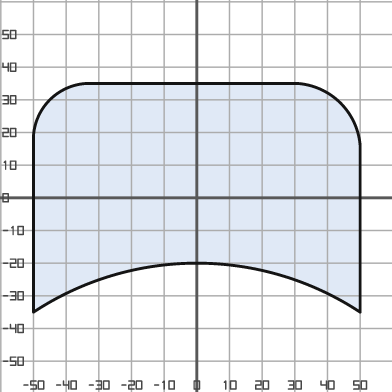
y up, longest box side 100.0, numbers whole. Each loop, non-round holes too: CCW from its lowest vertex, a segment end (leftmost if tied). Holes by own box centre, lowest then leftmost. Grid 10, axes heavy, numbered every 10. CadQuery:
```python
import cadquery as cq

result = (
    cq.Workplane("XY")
    .moveTo(-50.0, -35.0)
    .threePointArc((0.0, -20.0), (50.0, -35.0))
    .lineTo(50.0, 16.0)
    .threePointArc((44.0, 29.0), (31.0, 35.0))
    .lineTo(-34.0, 35.0)
    .threePointArc((-45.0, 30.0), (-50.0, 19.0))
    .close()
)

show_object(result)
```